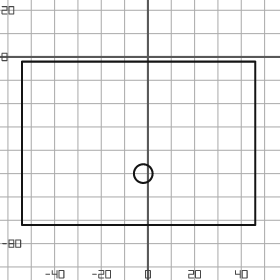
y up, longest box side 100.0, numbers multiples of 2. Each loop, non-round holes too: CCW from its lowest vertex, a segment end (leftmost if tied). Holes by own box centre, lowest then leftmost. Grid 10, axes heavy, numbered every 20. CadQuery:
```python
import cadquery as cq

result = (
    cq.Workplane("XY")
    .moveTo(-54.0, -72.0)
    .lineTo(46.0, -72.0)
    .lineTo(46.0, -2.0)
    .lineTo(-54.0, -2.0)
    .close()
    .moveTo(-2.0, -50.0)
    .circle(4.0)
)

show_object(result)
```